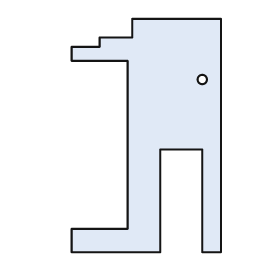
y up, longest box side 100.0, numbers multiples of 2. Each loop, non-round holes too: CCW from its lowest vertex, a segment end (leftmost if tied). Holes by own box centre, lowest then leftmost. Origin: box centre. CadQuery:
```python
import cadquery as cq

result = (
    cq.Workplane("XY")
    .moveTo(-32.0, -50.0)
    .lineTo(6.0, -50.0)
    .lineTo(6.0, -6.0)
    .lineTo(24.0, -6.0)
    .lineTo(24.0, -50.0)
    .lineTo(32.0, -50.0)
    .lineTo(32.0, 50.0)
    .lineTo(-6.0, 50.0)
    .lineTo(-6.0, 42.0)
    .lineTo(-20.0, 42.0)
    .lineTo(-20.0, 38.0)
    .lineTo(-32.0, 38.0)
    .lineTo(-32.0, 32.0)
    .lineTo(-8.0, 32.0)
    .lineTo(-8.0, -40.0)
    .lineTo(-32.0, -40.0)
    .close()
    .moveTo(24.0, 24.0)
    .circle(2.0)
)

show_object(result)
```